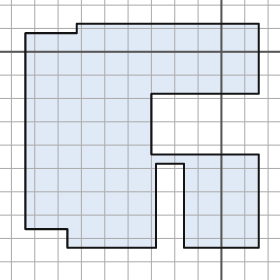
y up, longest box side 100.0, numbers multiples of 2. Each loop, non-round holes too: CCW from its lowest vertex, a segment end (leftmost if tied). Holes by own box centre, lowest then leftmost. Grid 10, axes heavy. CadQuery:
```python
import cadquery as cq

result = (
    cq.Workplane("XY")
    .moveTo(-66.0, -84.0)
    .lineTo(-28.0, -84.0)
    .lineTo(-28.0, -48.0)
    .lineTo(-16.0, -48.0)
    .lineTo(-16.0, -84.0)
    .lineTo(16.0, -84.0)
    .lineTo(16.0, -44.0)
    .lineTo(-30.0, -44.0)
    .lineTo(-30.0, -18.0)
    .lineTo(16.0, -18.0)
    .lineTo(16.0, 12.0)
    .lineTo(-62.0, 12.0)
    .lineTo(-62.0, 8.0)
    .lineTo(-84.0, 8.0)
    .lineTo(-84.0, -76.0)
    .lineTo(-66.0, -76.0)
    .close()
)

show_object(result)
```